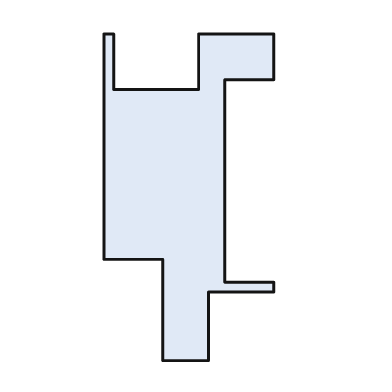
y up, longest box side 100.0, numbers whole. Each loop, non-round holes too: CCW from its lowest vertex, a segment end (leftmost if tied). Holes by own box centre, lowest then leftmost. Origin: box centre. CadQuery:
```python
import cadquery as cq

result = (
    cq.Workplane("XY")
    .moveTo(-8.0, -50.0)
    .lineTo(6.0, -50.0)
    .lineTo(6.0, -29.0)
    .lineTo(26.0, -29.0)
    .lineTo(26.0, -26.0)
    .lineTo(11.0, -26.0)
    .lineTo(11.0, 36.0)
    .lineTo(26.0, 36.0)
    .lineTo(26.0, 50.0)
    .lineTo(3.0, 50.0)
    .lineTo(3.0, 33.0)
    .lineTo(-23.0, 33.0)
    .lineTo(-23.0, 50.0)
    .lineTo(-26.0, 50.0)
    .lineTo(-26.0, -19.0)
    .lineTo(-8.0, -19.0)
    .close()
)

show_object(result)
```